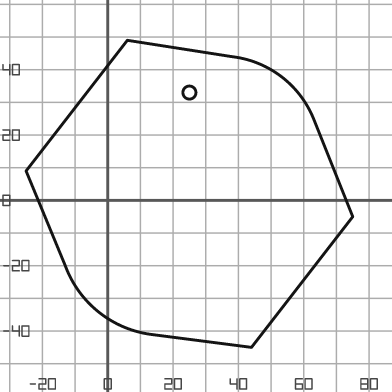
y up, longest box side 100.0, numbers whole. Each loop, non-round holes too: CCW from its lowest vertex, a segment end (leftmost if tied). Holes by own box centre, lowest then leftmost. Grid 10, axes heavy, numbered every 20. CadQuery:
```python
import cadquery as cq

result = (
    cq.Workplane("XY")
    .moveTo(44.0, -45.0)
    .lineTo(75.0, -5.0)
    .lineTo(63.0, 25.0)
    .threePointArc((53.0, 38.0), (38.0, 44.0))
    .lineTo(6.0, 49.0)
    .lineTo(-25.0, 9.0)
    .lineTo(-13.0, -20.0)
    .threePointArc((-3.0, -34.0), (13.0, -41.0))
    .close()
    .moveTo(25.0, 33.0)
    .circle(2.0)
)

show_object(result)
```